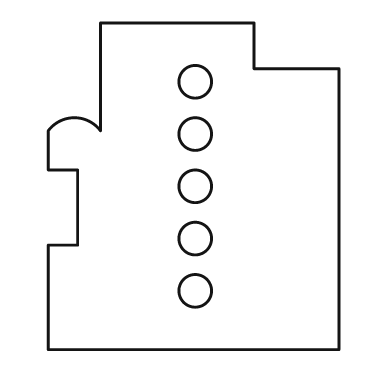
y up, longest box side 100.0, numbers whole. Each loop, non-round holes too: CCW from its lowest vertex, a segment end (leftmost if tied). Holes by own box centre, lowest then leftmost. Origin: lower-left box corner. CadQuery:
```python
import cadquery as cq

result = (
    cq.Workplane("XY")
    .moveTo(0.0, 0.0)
    .lineTo(89.0, 0.0)
    .lineTo(89.0, 86.0)
    .lineTo(63.0, 86.0)
    .lineTo(63.0, 100.0)
    .lineTo(16.0, 100.0)
    .lineTo(16.0, 67.0)
    .threePointArc((8.0, 71.0), (0.0, 67.0))
    .lineTo(0.0, 55.0)
    .lineTo(9.0, 55.0)
    .lineTo(9.0, 32.0)
    .lineTo(0.0, 32.0)
    .close()
    .moveTo(45.0, 18.0)
    .circle(5.0)
    .moveTo(45.0, 34.0)
    .circle(5.0)
    .moveTo(45.0, 50.0)
    .circle(5.0)
    .moveTo(45.0, 66.0)
    .circle(5.0)
    .moveTo(45.0, 82.0)
    .circle(5.0)
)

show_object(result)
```